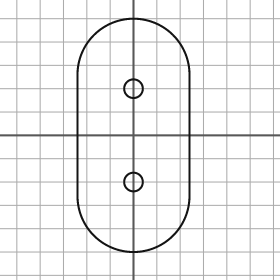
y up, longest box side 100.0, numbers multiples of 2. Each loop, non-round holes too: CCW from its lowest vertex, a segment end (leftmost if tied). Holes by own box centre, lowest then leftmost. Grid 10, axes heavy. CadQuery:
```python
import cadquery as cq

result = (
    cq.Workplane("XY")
    .moveTo(-24.0, -26.0)
    .threePointArc((0.0, -50.0), (24.0, -26.0))
    .lineTo(24.0, 26.0)
    .threePointArc((0.0, 50.0), (-24.0, 26.0))
    .close()
    .moveTo(0.0, -20.0)
    .circle(4.0)
    .moveTo(0.0, 20.0)
    .circle(4.0)
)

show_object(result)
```